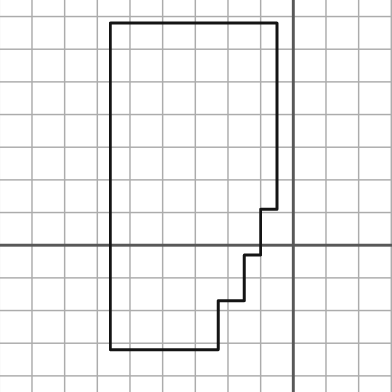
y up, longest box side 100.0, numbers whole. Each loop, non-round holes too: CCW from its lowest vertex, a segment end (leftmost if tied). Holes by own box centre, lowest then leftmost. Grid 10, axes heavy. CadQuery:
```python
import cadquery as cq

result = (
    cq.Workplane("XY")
    .moveTo(-56.0, -32.0)
    .lineTo(-23.0, -32.0)
    .lineTo(-23.0, -17.0)
    .lineTo(-15.0, -17.0)
    .lineTo(-15.0, -3.0)
    .lineTo(-10.0, -3.0)
    .lineTo(-10.0, 11.0)
    .lineTo(-5.0, 11.0)
    .lineTo(-5.0, 68.0)
    .lineTo(-56.0, 68.0)
    .close()
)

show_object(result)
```